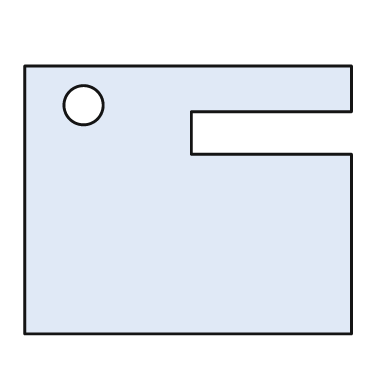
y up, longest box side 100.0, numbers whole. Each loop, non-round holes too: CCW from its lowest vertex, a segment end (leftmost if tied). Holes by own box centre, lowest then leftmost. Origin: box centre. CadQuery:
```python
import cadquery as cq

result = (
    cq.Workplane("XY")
    .moveTo(-50.0, -41.0)
    .lineTo(50.0, -41.0)
    .lineTo(50.0, 14.0)
    .lineTo(1.0, 14.0)
    .lineTo(1.0, 27.0)
    .lineTo(50.0, 27.0)
    .lineTo(50.0, 41.0)
    .lineTo(-50.0, 41.0)
    .close()
    .moveTo(-32.0, 29.0)
    .circle(6.0)
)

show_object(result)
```